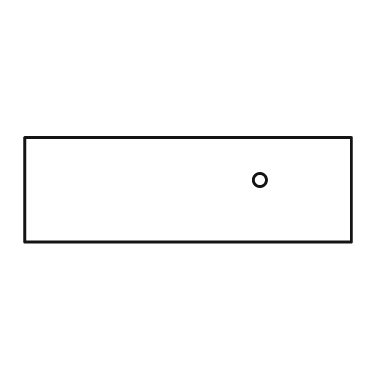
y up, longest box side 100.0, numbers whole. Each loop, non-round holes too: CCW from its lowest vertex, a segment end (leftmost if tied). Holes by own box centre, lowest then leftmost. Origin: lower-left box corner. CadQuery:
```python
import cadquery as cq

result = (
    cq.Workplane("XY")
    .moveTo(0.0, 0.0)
    .lineTo(100.0, 0.0)
    .lineTo(100.0, 32.0)
    .lineTo(0.0, 32.0)
    .close()
    .moveTo(72.0, 19.0)
    .circle(2.0)
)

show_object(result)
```